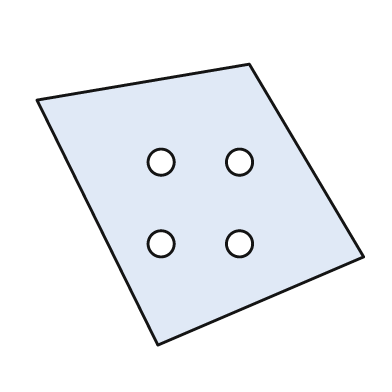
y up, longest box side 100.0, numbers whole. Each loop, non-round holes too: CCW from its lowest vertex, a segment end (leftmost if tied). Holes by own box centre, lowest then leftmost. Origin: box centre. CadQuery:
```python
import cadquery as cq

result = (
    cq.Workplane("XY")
    .moveTo(-13.0, -43.0)
    .lineTo(50.0, -16.0)
    .lineTo(15.0, 43.0)
    .lineTo(-50.0, 32.0)
    .close()
    .moveTo(-12.0, -12.0)
    .circle(4.0)
    .moveTo(12.0, -12.0)
    .circle(4.0)
    .moveTo(-12.0, 13.0)
    .circle(4.0)
    .moveTo(12.0, 13.0)
    .circle(4.0)
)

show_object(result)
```